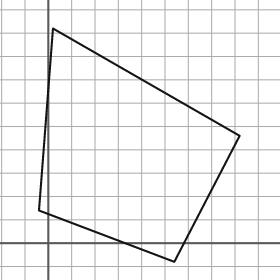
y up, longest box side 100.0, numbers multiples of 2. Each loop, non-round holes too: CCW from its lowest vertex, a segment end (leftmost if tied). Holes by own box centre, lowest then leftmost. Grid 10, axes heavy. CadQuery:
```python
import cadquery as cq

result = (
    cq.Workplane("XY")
    .moveTo(54.0, -8.0)
    .lineTo(82.0, 46.0)
    .lineTo(2.0, 92.0)
    .lineTo(-4.0, 14.0)
    .close()
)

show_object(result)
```